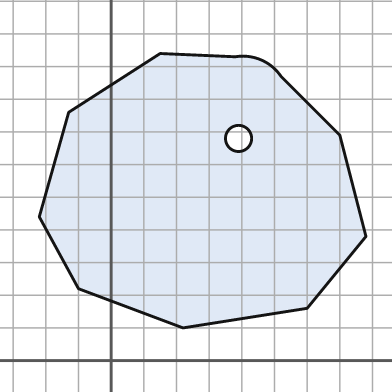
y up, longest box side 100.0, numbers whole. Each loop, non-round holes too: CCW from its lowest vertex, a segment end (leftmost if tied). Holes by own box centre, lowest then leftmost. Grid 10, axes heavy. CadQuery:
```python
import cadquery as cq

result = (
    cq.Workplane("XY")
    .moveTo(22.0, 10.0)
    .lineTo(60.0, 16.0)
    .lineTo(78.0, 38.0)
    .lineTo(70.0, 69.0)
    .lineTo(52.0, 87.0)
    .threePointArc((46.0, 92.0), (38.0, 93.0))
    .lineTo(15.0, 94.0)
    .lineTo(-13.0, 76.0)
    .lineTo(-22.0, 44.0)
    .lineTo(-10.0, 22.0)
    .close()
    .moveTo(39.0, 68.0)
    .circle(4.0)
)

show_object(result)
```